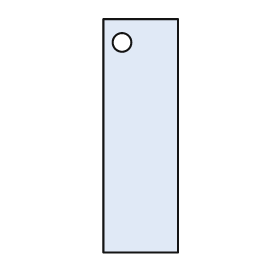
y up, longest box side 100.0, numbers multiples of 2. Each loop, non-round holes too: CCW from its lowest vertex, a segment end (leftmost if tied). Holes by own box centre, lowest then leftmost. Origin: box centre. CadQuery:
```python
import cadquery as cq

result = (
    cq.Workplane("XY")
    .moveTo(-16.0, -50.0)
    .lineTo(16.0, -50.0)
    .lineTo(16.0, 50.0)
    .lineTo(-16.0, 50.0)
    .close()
    .moveTo(-8.0, 40.0)
    .circle(4.0)
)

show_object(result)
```